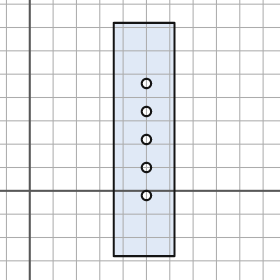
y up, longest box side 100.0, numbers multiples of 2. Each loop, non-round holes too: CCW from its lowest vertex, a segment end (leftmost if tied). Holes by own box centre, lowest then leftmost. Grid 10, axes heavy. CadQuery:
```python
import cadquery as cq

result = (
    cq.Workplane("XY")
    .moveTo(36.0, -28.0)
    .lineTo(62.0, -28.0)
    .lineTo(62.0, 72.0)
    .lineTo(36.0, 72.0)
    .close()
    .moveTo(50.0, -2.0)
    .circle(2.0)
    .moveTo(50.0, 10.0)
    .circle(2.0)
    .moveTo(50.0, 22.0)
    .circle(2.0)
    .moveTo(50.0, 34.0)
    .circle(2.0)
    .moveTo(50.0, 46.0)
    .circle(2.0)
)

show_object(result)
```